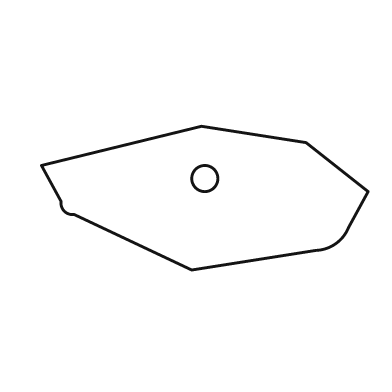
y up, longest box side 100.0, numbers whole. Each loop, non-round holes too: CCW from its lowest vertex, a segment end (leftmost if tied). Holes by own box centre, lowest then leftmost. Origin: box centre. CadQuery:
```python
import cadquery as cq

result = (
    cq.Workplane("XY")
    .moveTo(-4.0, -22.0)
    .lineTo(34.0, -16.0)
    .threePointArc((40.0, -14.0), (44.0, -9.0))
    .lineTo(50.0, 2.0)
    .lineTo(31.0, 17.0)
    .lineTo(-1.0, 22.0)
    .lineTo(-50.0, 10.0)
    .lineTo(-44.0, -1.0)
    .threePointArc((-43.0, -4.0), (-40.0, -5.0))
    .close()
    .moveTo(0.0, 6.0)
    .circle(4.0)
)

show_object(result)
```